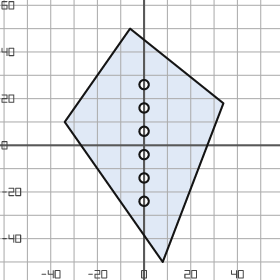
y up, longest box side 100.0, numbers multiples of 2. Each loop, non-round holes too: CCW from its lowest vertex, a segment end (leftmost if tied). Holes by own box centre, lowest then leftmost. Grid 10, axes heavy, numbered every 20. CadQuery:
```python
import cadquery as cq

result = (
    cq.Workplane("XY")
    .moveTo(8.0, -50.0)
    .lineTo(34.0, 18.0)
    .lineTo(-6.0, 50.0)
    .lineTo(-34.0, 10.0)
    .close()
    .moveTo(0.0, -24.0)
    .circle(2.0)
    .moveTo(0.0, -14.0)
    .circle(2.0)
    .moveTo(0.0, -4.0)
    .circle(2.0)
    .moveTo(0.0, 6.0)
    .circle(2.0)
    .moveTo(0.0, 16.0)
    .circle(2.0)
    .moveTo(0.0, 26.0)
    .circle(2.0)
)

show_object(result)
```